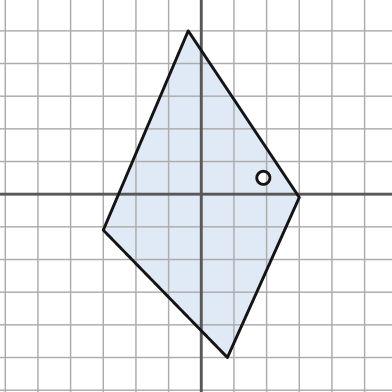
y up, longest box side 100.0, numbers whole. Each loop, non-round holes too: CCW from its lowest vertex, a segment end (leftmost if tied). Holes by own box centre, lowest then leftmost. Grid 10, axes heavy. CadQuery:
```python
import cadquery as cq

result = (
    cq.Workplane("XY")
    .moveTo(8.0, -50.0)
    .lineTo(30.0, -1.0)
    .lineTo(-4.0, 50.0)
    .lineTo(-30.0, -11.0)
    .close()
    .moveTo(19.0, 5.0)
    .circle(2.0)
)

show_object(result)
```